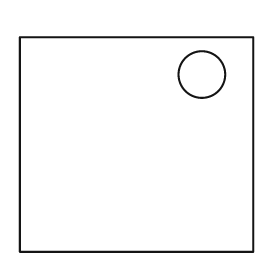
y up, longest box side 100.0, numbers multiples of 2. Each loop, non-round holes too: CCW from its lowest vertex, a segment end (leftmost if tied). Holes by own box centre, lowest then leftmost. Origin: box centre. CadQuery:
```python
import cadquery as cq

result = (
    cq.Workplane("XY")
    .moveTo(-50.0, -46.0)
    .lineTo(50.0, -46.0)
    .lineTo(50.0, 46.0)
    .lineTo(-50.0, 46.0)
    .close()
    .moveTo(28.0, 30.0)
    .circle(10.0)
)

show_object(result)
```